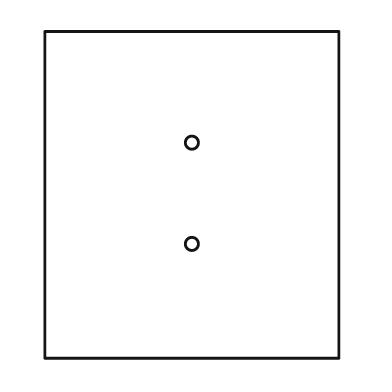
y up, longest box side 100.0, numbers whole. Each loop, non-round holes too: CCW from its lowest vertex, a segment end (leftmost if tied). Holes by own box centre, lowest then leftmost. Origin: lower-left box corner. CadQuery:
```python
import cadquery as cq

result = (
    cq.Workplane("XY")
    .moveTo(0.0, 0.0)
    .lineTo(90.0, 0.0)
    .lineTo(90.0, 100.0)
    .lineTo(0.0, 100.0)
    .close()
    .moveTo(45.0, 35.0)
    .circle(2.0)
    .moveTo(45.0, 66.0)
    .circle(2.0)
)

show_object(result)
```